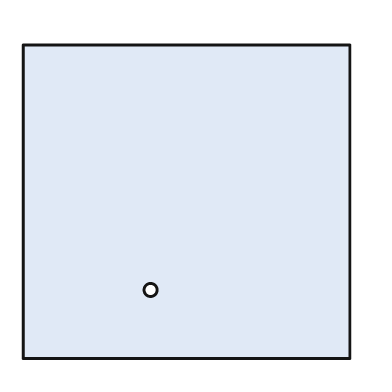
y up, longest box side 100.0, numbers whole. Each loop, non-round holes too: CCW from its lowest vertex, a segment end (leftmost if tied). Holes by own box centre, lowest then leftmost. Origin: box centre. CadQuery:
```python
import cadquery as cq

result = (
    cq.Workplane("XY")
    .moveTo(-50.0, -48.0)
    .lineTo(50.0, -48.0)
    .lineTo(50.0, 48.0)
    .lineTo(-50.0, 48.0)
    .close()
    .moveTo(-11.0, -27.0)
    .circle(2.0)
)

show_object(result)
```